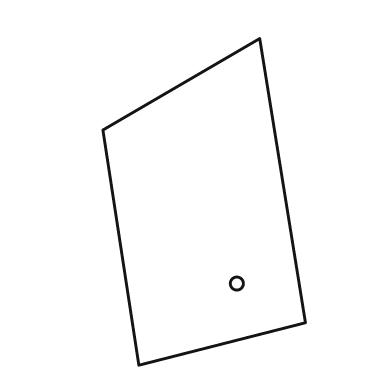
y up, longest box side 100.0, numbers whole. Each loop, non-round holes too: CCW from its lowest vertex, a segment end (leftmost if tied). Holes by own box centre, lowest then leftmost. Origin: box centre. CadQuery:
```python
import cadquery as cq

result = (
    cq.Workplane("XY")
    .moveTo(-20.0, -50.0)
    .lineTo(31.0, -37.0)
    .lineTo(17.0, 50.0)
    .lineTo(-31.0, 22.0)
    .close()
    .moveTo(10.0, -25.0)
    .circle(2.0)
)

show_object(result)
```